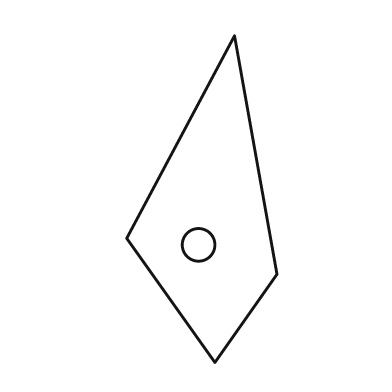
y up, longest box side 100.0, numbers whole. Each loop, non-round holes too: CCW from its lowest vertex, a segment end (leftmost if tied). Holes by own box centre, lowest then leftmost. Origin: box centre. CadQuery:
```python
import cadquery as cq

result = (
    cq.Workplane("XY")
    .moveTo(4.0, -50.0)
    .lineTo(23.0, -23.0)
    .lineTo(10.0, 50.0)
    .lineTo(-23.0, -12.0)
    .close()
    .moveTo(-1.0, -14.0)
    .circle(5.0)
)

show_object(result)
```